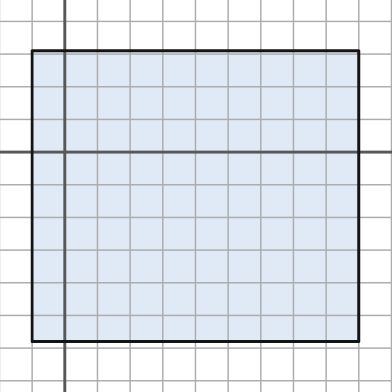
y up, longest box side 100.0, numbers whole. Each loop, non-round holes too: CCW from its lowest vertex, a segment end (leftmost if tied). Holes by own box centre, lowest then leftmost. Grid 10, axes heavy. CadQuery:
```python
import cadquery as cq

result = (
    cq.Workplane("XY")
    .moveTo(-10.0, -58.0)
    .lineTo(90.0, -58.0)
    .lineTo(90.0, 31.0)
    .lineTo(-10.0, 31.0)
    .close()
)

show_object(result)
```